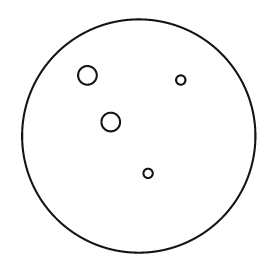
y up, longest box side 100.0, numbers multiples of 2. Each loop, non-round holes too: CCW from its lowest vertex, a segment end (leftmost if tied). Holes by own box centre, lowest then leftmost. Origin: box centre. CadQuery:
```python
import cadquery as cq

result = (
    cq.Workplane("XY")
    .moveTo(0.0, 0.0)
    .circle(50.0)
    .moveTo(4.0, -16.0)
    .circle(2.0)
    .moveTo(-12.0, 6.0)
    .circle(4.0)
    .moveTo(18.0, 24.0)
    .circle(2.0)
    .moveTo(-22.0, 26.0)
    .circle(4.0)
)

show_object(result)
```